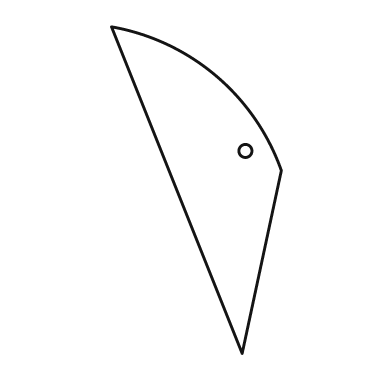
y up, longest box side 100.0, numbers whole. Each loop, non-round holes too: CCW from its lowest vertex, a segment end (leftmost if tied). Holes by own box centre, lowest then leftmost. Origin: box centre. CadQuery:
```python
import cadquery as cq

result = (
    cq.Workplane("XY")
    .moveTo(14.0, -50.0)
    .lineTo(26.0, 6.0)
    .threePointArc((6.0, 35.0), (-26.0, 50.0))
    .close()
    .moveTo(15.0, 12.0)
    .circle(2.0)
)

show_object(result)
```